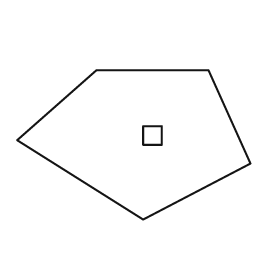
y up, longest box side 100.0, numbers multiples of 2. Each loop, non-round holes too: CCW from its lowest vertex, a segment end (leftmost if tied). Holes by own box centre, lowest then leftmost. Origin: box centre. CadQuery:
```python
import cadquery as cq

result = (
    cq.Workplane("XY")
    .moveTo(4.0, -32.0)
    .lineTo(50.0, -8.0)
    .lineTo(32.0, 32.0)
    .lineTo(-16.0, 32.0)
    .lineTo(-50.0, 2.0)
    .close()
    .moveTo(4.0, 0.0)
    .lineTo(12.0, 0.0)
    .lineTo(12.0, 8.0)
    .lineTo(4.0, 8.0)
    .close()
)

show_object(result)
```